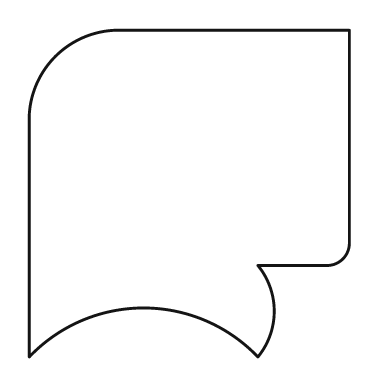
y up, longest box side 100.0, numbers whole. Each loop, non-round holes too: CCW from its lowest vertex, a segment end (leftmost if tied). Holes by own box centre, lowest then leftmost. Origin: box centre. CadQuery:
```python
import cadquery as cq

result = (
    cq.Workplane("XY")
    .moveTo(-49.0, -50.0)
    .threePointArc((-14.0, -35.0), (21.0, -50.0))
    .threePointArc((26.0, -36.0), (21.0, -22.0))
    .lineTo(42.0, -22.0)
    .threePointArc((47.0, -20.0), (49.0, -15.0))
    .lineTo(49.0, 50.0)
    .lineTo(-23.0, 50.0)
    .threePointArc((-41.0, 42.0), (-49.0, 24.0))
    .close()
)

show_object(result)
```